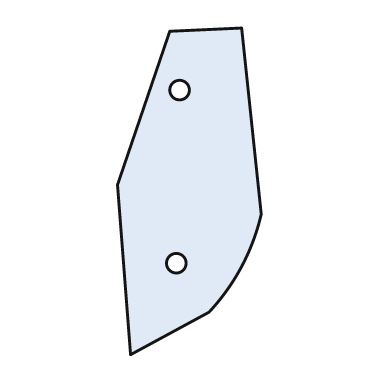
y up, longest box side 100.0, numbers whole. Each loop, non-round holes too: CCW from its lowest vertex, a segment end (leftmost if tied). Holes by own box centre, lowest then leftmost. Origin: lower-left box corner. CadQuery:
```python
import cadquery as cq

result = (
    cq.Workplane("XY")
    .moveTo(4.0, 0.0)
    .lineTo(28.0, 13.0)
    .threePointArc((38.0, 27.0), (44.0, 43.0))
    .lineTo(38.0, 100.0)
    .lineTo(16.0, 99.0)
    .lineTo(0.0, 52.0)
    .close()
    .moveTo(18.0, 28.0)
    .circle(3.0)
    .moveTo(19.0, 81.0)
    .circle(3.0)
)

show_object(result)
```